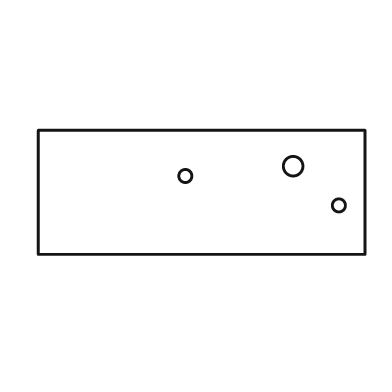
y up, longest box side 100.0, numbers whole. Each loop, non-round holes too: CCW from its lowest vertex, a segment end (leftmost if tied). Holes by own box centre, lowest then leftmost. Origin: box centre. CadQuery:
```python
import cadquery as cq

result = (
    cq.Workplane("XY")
    .moveTo(-50.0, -19.0)
    .lineTo(50.0, -19.0)
    .lineTo(50.0, 19.0)
    .lineTo(-50.0, 19.0)
    .close()
    .moveTo(42.0, -4.0)
    .circle(2.0)
    .moveTo(-5.0, 5.0)
    .circle(2.0)
    .moveTo(28.0, 8.0)
    .circle(3.0)
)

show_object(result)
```